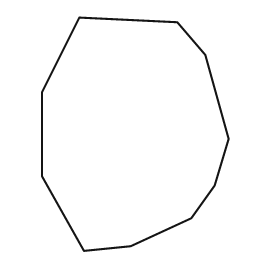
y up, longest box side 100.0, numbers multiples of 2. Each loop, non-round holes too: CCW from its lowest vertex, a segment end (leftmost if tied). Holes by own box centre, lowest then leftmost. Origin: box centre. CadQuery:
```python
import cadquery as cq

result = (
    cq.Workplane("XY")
    .moveTo(-22.0, -50.0)
    .lineTo(-2.0, -48.0)
    .lineTo(24.0, -36.0)
    .lineTo(34.0, -22.0)
    .lineTo(40.0, -2.0)
    .lineTo(30.0, 34.0)
    .lineTo(18.0, 48.0)
    .lineTo(-24.0, 50.0)
    .lineTo(-40.0, 18.0)
    .lineTo(-40.0, -18.0)
    .close()
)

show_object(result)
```